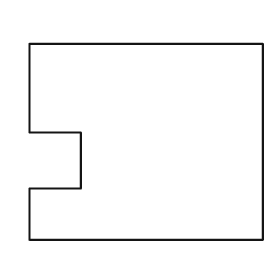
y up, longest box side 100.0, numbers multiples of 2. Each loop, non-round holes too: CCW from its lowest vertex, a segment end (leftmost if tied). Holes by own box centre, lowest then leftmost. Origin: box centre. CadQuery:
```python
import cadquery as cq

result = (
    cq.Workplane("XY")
    .moveTo(-50.0, -42.0)
    .lineTo(50.0, -42.0)
    .lineTo(50.0, 42.0)
    .lineTo(-50.0, 42.0)
    .lineTo(-50.0, 4.0)
    .lineTo(-28.0, 4.0)
    .lineTo(-28.0, -20.0)
    .lineTo(-50.0, -20.0)
    .close()
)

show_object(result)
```